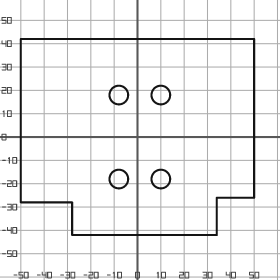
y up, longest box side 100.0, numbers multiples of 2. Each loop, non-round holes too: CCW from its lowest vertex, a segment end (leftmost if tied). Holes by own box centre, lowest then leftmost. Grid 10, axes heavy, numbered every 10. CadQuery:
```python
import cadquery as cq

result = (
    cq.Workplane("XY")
    .moveTo(-28.0, -42.0)
    .lineTo(34.0, -42.0)
    .lineTo(34.0, -26.0)
    .lineTo(50.0, -26.0)
    .lineTo(50.0, 42.0)
    .lineTo(-50.0, 42.0)
    .lineTo(-50.0, -28.0)
    .lineTo(-28.0, -28.0)
    .close()
    .moveTo(-8.0, -18.0)
    .circle(4.0)
    .moveTo(10.0, -18.0)
    .circle(4.0)
    .moveTo(-8.0, 18.0)
    .circle(4.0)
    .moveTo(10.0, 18.0)
    .circle(4.0)
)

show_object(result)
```